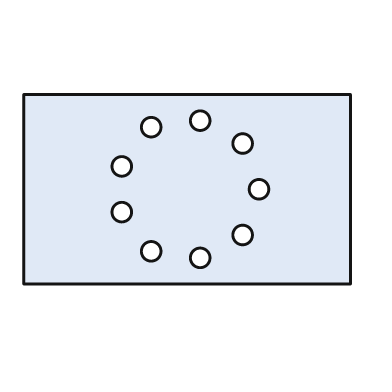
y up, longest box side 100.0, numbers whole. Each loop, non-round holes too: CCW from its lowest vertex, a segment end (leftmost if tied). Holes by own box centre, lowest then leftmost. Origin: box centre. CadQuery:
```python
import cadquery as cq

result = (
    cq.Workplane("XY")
    .moveTo(-50.0, -29.0)
    .lineTo(50.0, -29.0)
    .lineTo(50.0, 29.0)
    .lineTo(-50.0, 29.0)
    .close()
    .moveTo(4.0, -21.0)
    .circle(3.0)
    .moveTo(-11.0, -19.0)
    .circle(3.0)
    .moveTo(17.0, -14.0)
    .circle(3.0)
    .moveTo(-20.0, -7.0)
    .circle(3.0)
    .moveTo(22.0, 0.0)
    .circle(3.0)
    .moveTo(-20.0, 7.0)
    .circle(3.0)
    .moveTo(17.0, 14.0)
    .circle(3.0)
    .moveTo(-11.0, 19.0)
    .circle(3.0)
    .moveTo(4.0, 21.0)
    .circle(3.0)
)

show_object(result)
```